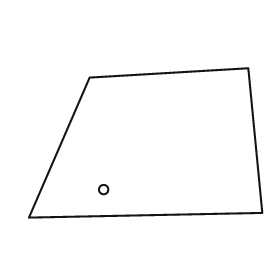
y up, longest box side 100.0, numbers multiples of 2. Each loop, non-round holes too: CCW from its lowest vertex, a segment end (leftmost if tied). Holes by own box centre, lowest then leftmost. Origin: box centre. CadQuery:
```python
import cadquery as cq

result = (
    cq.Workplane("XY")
    .moveTo(-50.0, -32.0)
    .lineTo(50.0, -30.0)
    .lineTo(44.0, 32.0)
    .lineTo(-24.0, 28.0)
    .close()
    .moveTo(-18.0, -20.0)
    .circle(2.0)
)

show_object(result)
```